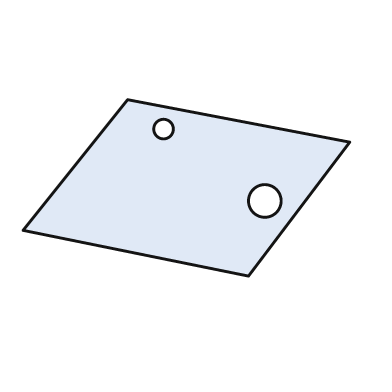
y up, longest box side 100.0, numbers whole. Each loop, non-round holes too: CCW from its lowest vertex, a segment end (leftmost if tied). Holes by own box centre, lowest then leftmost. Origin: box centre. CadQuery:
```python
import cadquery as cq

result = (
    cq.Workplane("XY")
    .moveTo(19.0, -27.0)
    .lineTo(50.0, 14.0)
    .lineTo(-18.0, 27.0)
    .lineTo(-50.0, -13.0)
    .close()
    .moveTo(24.0, -4.0)
    .circle(5.0)
    .moveTo(-7.0, 18.0)
    .circle(3.0)
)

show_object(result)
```